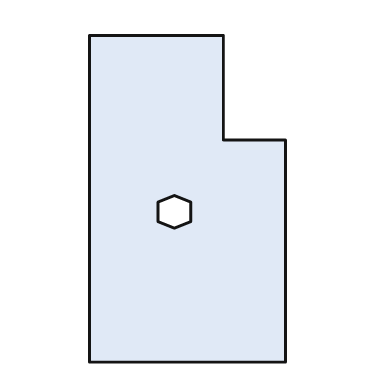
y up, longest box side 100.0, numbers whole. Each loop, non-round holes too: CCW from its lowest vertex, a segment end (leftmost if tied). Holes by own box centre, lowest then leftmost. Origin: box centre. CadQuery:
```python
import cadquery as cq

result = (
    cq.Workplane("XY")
    .moveTo(-30.0, -50.0)
    .lineTo(30.0, -50.0)
    .lineTo(30.0, 18.0)
    .lineTo(11.0, 18.0)
    .lineTo(11.0, 50.0)
    .lineTo(-30.0, 50.0)
    .close()
    .moveTo(-4.0, -9.0)
    .lineTo(1.0, -7.0)
    .lineTo(1.0, -1.0)
    .lineTo(-4.0, 1.0)
    .lineTo(-9.0, -1.0)
    .lineTo(-9.0, -7.0)
    .close()
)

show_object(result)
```